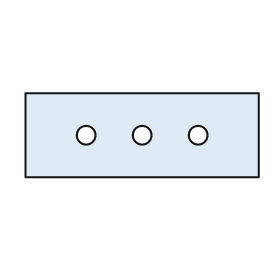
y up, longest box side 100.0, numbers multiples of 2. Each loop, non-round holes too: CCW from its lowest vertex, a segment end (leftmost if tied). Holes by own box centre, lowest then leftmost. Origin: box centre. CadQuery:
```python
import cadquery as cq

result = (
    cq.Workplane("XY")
    .moveTo(-50.0, -18.0)
    .lineTo(50.0, -18.0)
    .lineTo(50.0, 18.0)
    .lineTo(-50.0, 18.0)
    .close()
    .moveTo(-24.0, 0.0)
    .circle(4.0)
    .moveTo(0.0, 0.0)
    .circle(4.0)
    .moveTo(24.0, 0.0)
    .circle(4.0)
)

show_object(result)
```